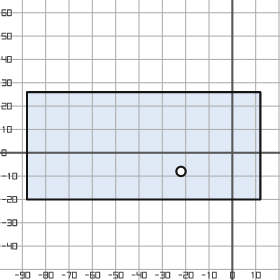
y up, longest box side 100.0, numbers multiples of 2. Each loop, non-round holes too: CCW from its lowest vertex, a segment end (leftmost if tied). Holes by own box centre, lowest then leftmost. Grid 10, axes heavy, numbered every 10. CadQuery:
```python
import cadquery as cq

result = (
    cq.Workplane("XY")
    .moveTo(-88.0, -20.0)
    .lineTo(12.0, -20.0)
    .lineTo(12.0, 26.0)
    .lineTo(-88.0, 26.0)
    .close()
    .moveTo(-22.0, -8.0)
    .circle(2.0)
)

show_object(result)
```